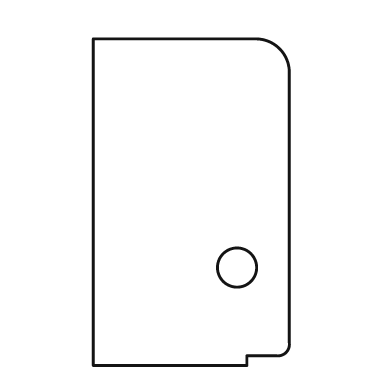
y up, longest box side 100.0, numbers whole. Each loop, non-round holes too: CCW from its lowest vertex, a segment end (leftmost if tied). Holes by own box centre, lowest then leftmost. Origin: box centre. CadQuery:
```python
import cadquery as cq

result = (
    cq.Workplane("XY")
    .moveTo(-30.0, -50.0)
    .lineTo(17.0, -50.0)
    .lineTo(17.0, -47.0)
    .lineTo(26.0, -47.0)
    .threePointArc((29.0, -46.0), (30.0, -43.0))
    .lineTo(30.0, 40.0)
    .threePointArc((27.0, 47.0), (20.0, 50.0))
    .lineTo(-30.0, 50.0)
    .close()
    .moveTo(14.0, -20.0)
    .circle(6.0)
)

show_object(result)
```